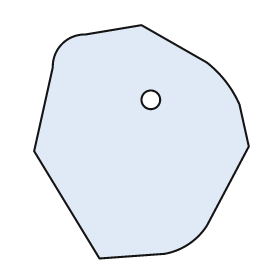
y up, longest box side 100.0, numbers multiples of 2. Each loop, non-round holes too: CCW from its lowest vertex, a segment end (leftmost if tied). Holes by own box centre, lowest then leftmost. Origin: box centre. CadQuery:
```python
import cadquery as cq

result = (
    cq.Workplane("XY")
    .moveTo(-18.0, -50.0)
    .lineTo(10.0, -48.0)
    .threePointArc((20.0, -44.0), (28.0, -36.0))
    .lineTo(46.0, -2.0)
    .lineTo(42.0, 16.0)
    .threePointArc((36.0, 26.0), (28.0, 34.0))
    .lineTo(0.0, 50.0)
    .lineTo(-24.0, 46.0)
    .threePointArc((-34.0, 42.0), (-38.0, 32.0))
    .lineTo(-46.0, -4.0)
    .close()
    .moveTo(4.0, 18.0)
    .circle(4.0)
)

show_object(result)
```